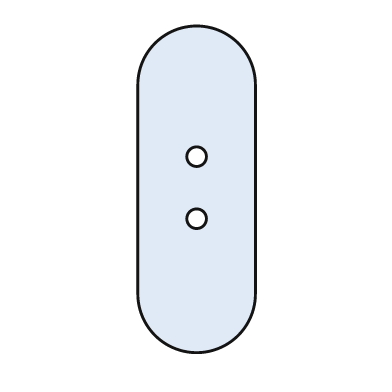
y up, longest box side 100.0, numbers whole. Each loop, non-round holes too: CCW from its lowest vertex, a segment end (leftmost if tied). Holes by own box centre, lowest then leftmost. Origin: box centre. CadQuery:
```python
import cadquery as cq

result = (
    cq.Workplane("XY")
    .moveTo(-18.0, -32.0)
    .threePointArc((0.0, -50.0), (18.0, -32.0))
    .lineTo(18.0, 32.0)
    .threePointArc((0.0, 50.0), (-18.0, 32.0))
    .close()
    .moveTo(0.0, -9.0)
    .circle(3.0)
    .moveTo(0.0, 10.0)
    .circle(3.0)
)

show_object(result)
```